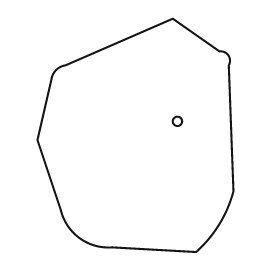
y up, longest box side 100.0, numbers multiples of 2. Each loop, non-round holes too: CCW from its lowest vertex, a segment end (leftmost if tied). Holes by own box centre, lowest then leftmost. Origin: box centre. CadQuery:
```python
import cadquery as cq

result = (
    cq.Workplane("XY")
    .moveTo(26.0, -50.0)
    .threePointArc((36.0, -38.0), (42.0, -24.0))
    .lineTo(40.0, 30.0)
    .threePointArc((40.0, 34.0), (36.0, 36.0))
    .lineTo(16.0, 50.0)
    .lineTo(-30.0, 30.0)
    .threePointArc((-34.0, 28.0), (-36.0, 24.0))
    .lineTo(-42.0, -2.0)
    .lineTo(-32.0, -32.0)
    .threePointArc((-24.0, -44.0), (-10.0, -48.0))
    .close()
    .moveTo(18.0, 6.0)
    .circle(2.0)
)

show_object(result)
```